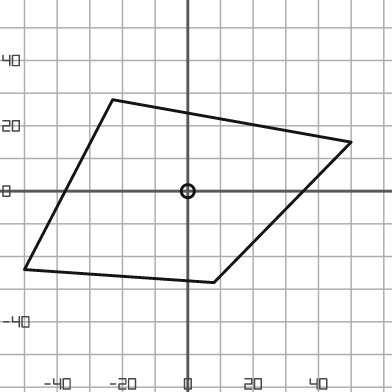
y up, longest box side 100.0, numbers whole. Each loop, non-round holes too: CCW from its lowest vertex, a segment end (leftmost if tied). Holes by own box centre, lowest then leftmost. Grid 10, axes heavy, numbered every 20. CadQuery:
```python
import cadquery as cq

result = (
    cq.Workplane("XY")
    .moveTo(8.0, -28.0)
    .lineTo(50.0, 15.0)
    .lineTo(-23.0, 28.0)
    .lineTo(-50.0, -24.0)
    .close()
    .moveTo(0.0, 0.0)
    .circle(2.0)
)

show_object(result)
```